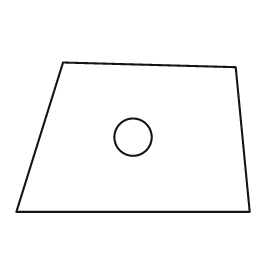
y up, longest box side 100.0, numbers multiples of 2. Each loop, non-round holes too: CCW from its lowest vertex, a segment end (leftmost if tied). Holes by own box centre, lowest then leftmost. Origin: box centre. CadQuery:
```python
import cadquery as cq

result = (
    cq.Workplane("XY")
    .moveTo(-50.0, -32.0)
    .lineTo(50.0, -32.0)
    .lineTo(44.0, 30.0)
    .lineTo(-30.0, 32.0)
    .close()
    .moveTo(0.0, 0.0)
    .circle(8.0)
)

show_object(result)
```